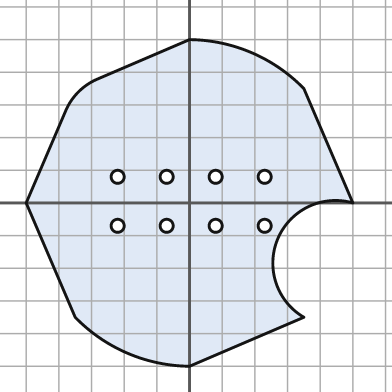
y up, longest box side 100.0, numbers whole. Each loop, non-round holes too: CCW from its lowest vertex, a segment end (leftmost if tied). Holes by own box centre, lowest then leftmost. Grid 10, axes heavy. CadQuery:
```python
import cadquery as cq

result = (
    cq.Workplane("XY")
    .moveTo(0.0, -50.0)
    .lineTo(35.0, -35.0)
    .threePointArc((27.0, -11.0), (50.0, 0.0))
    .lineTo(35.0, 35.0)
    .threePointArc((19.0, 46.0), (0.0, 50.0))
    .lineTo(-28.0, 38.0)
    .threePointArc((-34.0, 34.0), (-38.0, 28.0))
    .lineTo(-50.0, 0.0)
    .lineTo(-35.0, -35.0)
    .threePointArc((-19.0, -46.0), (0.0, -50.0))
    .close()
    .moveTo(-22.0, -7.0)
    .circle(2.0)
    .moveTo(-7.0, -7.0)
    .circle(2.0)
    .moveTo(8.0, -7.0)
    .circle(2.0)
    .moveTo(23.0, -7.0)
    .circle(2.0)
    .moveTo(-22.0, 8.0)
    .circle(2.0)
    .moveTo(-7.0, 8.0)
    .circle(2.0)
    .moveTo(8.0, 8.0)
    .circle(2.0)
    .moveTo(23.0, 8.0)
    .circle(2.0)
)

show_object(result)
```